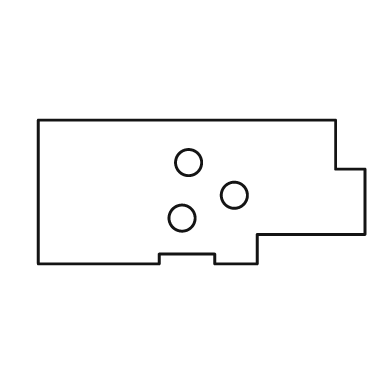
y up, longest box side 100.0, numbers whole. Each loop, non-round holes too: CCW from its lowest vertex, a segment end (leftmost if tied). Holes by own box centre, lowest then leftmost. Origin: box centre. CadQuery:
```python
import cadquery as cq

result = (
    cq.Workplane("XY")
    .moveTo(-50.0, -22.0)
    .lineTo(-13.0, -22.0)
    .lineTo(-13.0, -19.0)
    .lineTo(4.0, -19.0)
    .lineTo(4.0, -22.0)
    .lineTo(17.0, -22.0)
    .lineTo(17.0, -13.0)
    .lineTo(50.0, -13.0)
    .lineTo(50.0, 7.0)
    .lineTo(41.0, 7.0)
    .lineTo(41.0, 22.0)
    .lineTo(-50.0, 22.0)
    .close()
    .moveTo(-6.0, -8.0)
    .circle(4.0)
    .moveTo(10.0, -1.0)
    .circle(4.0)
    .moveTo(-4.0, 9.0)
    .circle(4.0)
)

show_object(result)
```